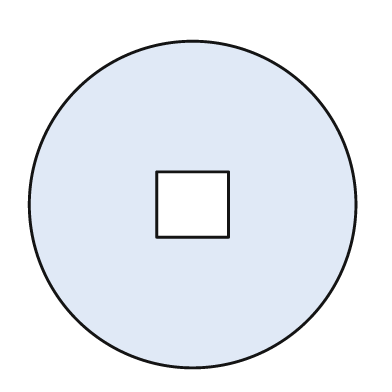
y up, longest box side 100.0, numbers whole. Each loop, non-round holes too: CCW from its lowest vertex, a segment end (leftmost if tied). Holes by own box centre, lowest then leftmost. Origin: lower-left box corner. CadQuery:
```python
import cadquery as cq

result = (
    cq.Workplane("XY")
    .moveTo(50.0, 50.0)
    .circle(50.0)
    .moveTo(39.0, 40.0)
    .lineTo(61.0, 40.0)
    .lineTo(61.0, 60.0)
    .lineTo(39.0, 60.0)
    .close()
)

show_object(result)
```